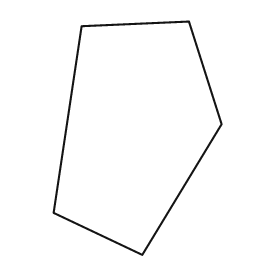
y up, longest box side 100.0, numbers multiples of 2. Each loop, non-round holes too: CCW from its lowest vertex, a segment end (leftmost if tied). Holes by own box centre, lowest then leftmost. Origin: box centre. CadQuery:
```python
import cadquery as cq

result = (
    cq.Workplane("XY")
    .moveTo(2.0, -50.0)
    .lineTo(36.0, 6.0)
    .lineTo(22.0, 50.0)
    .lineTo(-24.0, 48.0)
    .lineTo(-36.0, -32.0)
    .close()
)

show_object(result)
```